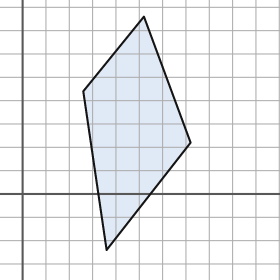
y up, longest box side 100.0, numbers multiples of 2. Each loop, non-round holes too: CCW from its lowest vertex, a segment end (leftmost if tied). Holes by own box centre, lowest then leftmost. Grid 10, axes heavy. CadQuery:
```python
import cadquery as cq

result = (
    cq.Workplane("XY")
    .moveTo(36.0, -24.0)
    .lineTo(72.0, 22.0)
    .lineTo(52.0, 76.0)
    .lineTo(26.0, 44.0)
    .close()
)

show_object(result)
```